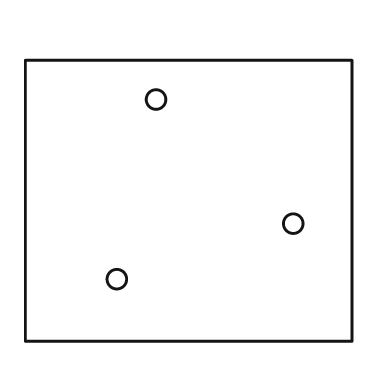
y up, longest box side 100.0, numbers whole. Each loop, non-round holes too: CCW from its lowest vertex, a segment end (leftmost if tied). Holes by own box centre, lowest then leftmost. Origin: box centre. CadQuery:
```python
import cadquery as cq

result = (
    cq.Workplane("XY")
    .moveTo(-50.0, -43.0)
    .lineTo(50.0, -43.0)
    .lineTo(50.0, 43.0)
    .lineTo(-50.0, 43.0)
    .close()
    .moveTo(-22.0, -24.0)
    .circle(3.0)
    .moveTo(32.0, -7.0)
    .circle(3.0)
    .moveTo(-10.0, 31.0)
    .circle(3.0)
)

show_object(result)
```